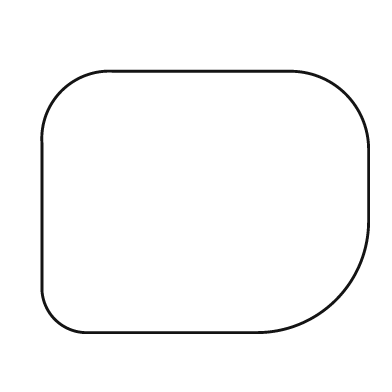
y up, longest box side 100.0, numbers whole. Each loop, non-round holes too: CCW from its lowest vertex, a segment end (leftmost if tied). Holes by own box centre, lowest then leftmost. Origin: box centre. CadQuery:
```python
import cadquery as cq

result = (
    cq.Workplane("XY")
    .moveTo(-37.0, -40.0)
    .lineTo(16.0, -40.0)
    .threePointArc((40.0, -30.0), (50.0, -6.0))
    .lineTo(50.0, 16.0)
    .threePointArc((43.0, 33.0), (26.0, 40.0))
    .lineTo(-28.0, 40.0)
    .threePointArc((-44.0, 34.0), (-50.0, 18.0))
    .lineTo(-50.0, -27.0)
    .threePointArc((-46.0, -36.0), (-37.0, -40.0))
    .close()
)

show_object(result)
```